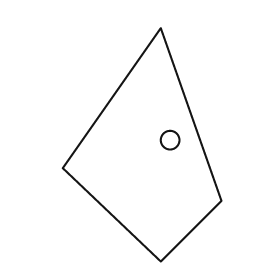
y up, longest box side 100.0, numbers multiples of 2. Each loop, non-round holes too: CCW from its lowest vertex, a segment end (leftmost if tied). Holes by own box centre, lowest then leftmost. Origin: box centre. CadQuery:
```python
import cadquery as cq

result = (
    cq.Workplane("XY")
    .moveTo(8.0, -50.0)
    .lineTo(34.0, -24.0)
    .lineTo(8.0, 50.0)
    .lineTo(-34.0, -10.0)
    .close()
    .moveTo(12.0, 2.0)
    .circle(4.0)
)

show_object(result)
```